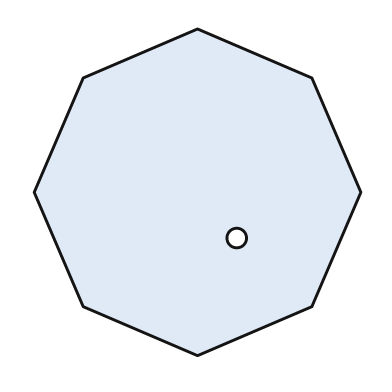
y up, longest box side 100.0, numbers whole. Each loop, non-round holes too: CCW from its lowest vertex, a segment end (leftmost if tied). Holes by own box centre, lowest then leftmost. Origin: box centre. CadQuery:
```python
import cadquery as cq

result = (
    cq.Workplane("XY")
    .moveTo(0.0, -50.0)
    .lineTo(35.0, -35.0)
    .lineTo(50.0, 0.0)
    .lineTo(35.0, 35.0)
    .lineTo(0.0, 50.0)
    .lineTo(-35.0, 35.0)
    .lineTo(-50.0, 0.0)
    .lineTo(-35.0, -35.0)
    .close()
    .moveTo(12.0, -14.0)
    .circle(3.0)
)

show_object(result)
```